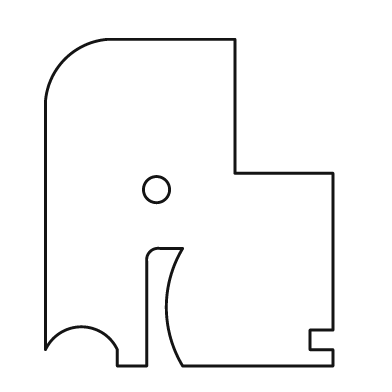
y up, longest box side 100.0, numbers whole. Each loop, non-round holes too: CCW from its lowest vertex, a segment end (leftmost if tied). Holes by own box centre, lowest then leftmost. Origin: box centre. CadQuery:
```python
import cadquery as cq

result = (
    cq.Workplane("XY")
    .moveTo(-22.0, -50.0)
    .lineTo(-13.0, -50.0)
    .lineTo(-13.0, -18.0)
    .threePointArc((-12.0, -15.0), (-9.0, -14.0))
    .lineTo(-2.0, -14.0)
    .threePointArc((-7.0, -32.0), (-2.0, -50.0))
    .lineTo(44.0, -50.0)
    .lineTo(44.0, -45.0)
    .lineTo(37.0, -45.0)
    .lineTo(37.0, -39.0)
    .lineTo(44.0, -39.0)
    .lineTo(44.0, 9.0)
    .lineTo(14.0, 9.0)
    .lineTo(14.0, 50.0)
    .lineTo(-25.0, 50.0)
    .threePointArc((-38.0, 44.0), (-44.0, 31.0))
    .lineTo(-44.0, -45.0)
    .threePointArc((-33.0, -38.0), (-22.0, -45.0))
    .close()
    .moveTo(-10.0, 4.0)
    .circle(4.0)
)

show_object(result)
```